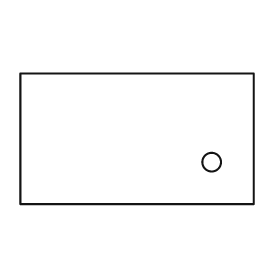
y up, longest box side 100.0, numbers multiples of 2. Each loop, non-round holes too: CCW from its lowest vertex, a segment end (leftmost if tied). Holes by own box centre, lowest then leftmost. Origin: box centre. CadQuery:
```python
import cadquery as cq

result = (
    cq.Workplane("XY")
    .moveTo(-50.0, -28.0)
    .lineTo(50.0, -28.0)
    .lineTo(50.0, 28.0)
    .lineTo(-50.0, 28.0)
    .close()
    .moveTo(32.0, -10.0)
    .circle(4.0)
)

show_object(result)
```